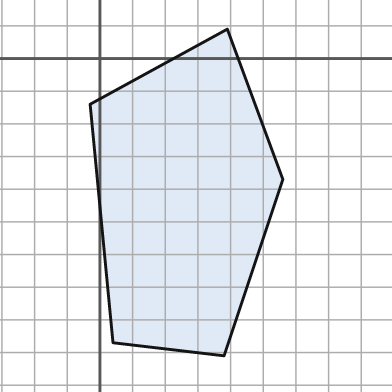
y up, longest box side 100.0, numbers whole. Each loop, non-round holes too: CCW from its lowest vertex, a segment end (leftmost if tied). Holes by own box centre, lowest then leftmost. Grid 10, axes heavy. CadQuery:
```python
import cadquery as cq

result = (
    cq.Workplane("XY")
    .moveTo(38.0, -91.0)
    .lineTo(56.0, -37.0)
    .lineTo(39.0, 9.0)
    .lineTo(-3.0, -14.0)
    .lineTo(4.0, -87.0)
    .close()
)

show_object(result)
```